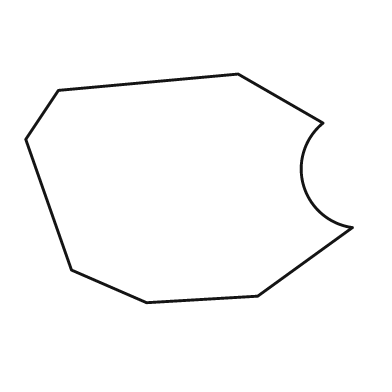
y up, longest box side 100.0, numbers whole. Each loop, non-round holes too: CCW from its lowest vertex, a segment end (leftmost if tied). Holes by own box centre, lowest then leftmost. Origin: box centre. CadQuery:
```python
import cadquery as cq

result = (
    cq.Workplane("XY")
    .moveTo(-13.0, -35.0)
    .lineTo(21.0, -33.0)
    .lineTo(50.0, -12.0)
    .threePointArc((35.0, 1.0), (41.0, 20.0))
    .lineTo(15.0, 35.0)
    .lineTo(-40.0, 30.0)
    .lineTo(-50.0, 15.0)
    .lineTo(-36.0, -25.0)
    .close()
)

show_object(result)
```